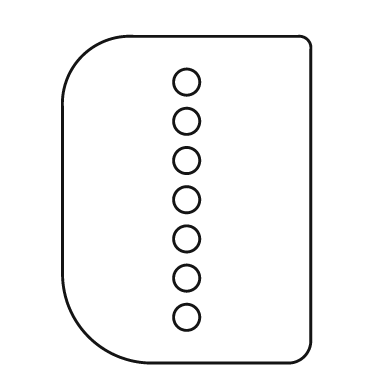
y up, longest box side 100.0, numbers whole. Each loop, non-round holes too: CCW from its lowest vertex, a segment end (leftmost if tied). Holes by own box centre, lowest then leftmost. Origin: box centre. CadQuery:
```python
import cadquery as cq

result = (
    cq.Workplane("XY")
    .moveTo(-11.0, -50.0)
    .lineTo(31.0, -50.0)
    .threePointArc((36.0, -48.0), (38.0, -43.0))
    .lineTo(38.0, 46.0)
    .threePointArc((37.0, 49.0), (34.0, 50.0))
    .lineTo(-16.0, 50.0)
    .threePointArc((-32.0, 44.0), (-38.0, 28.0))
    .lineTo(-38.0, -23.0)
    .threePointArc((-30.0, -42.0), (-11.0, -50.0))
    .close()
    .moveTo(0.0, -36.0)
    .circle(4.0)
    .moveTo(0.0, -24.0)
    .circle(4.0)
    .moveTo(0.0, -12.0)
    .circle(4.0)
    .moveTo(0.0, 0.0)
    .circle(4.0)
    .moveTo(0.0, 12.0)
    .circle(4.0)
    .moveTo(0.0, 24.0)
    .circle(4.0)
    .moveTo(0.0, 36.0)
    .circle(4.0)
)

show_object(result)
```